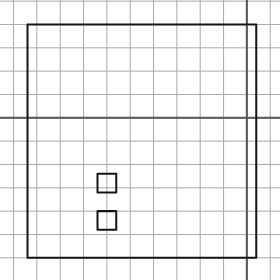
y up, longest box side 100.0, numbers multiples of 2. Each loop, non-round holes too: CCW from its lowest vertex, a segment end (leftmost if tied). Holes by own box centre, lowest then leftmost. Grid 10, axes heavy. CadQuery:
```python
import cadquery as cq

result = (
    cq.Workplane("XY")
    .moveTo(-94.0, -60.0)
    .lineTo(4.0, -60.0)
    .lineTo(4.0, 40.0)
    .lineTo(-94.0, 40.0)
    .close()
    .moveTo(-64.0, -48.0)
    .lineTo(-56.0, -48.0)
    .lineTo(-56.0, -40.0)
    .lineTo(-64.0, -40.0)
    .close()
    .moveTo(-64.0, -32.0)
    .lineTo(-56.0, -32.0)
    .lineTo(-56.0, -24.0)
    .lineTo(-64.0, -24.0)
    .close()
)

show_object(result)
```